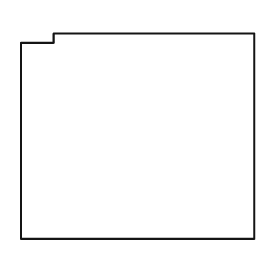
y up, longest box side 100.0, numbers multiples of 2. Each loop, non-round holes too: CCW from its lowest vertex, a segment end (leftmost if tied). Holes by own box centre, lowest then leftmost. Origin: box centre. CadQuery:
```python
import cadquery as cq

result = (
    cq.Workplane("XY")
    .moveTo(-50.0, -44.0)
    .lineTo(50.0, -44.0)
    .lineTo(50.0, 44.0)
    .lineTo(-36.0, 44.0)
    .lineTo(-36.0, 40.0)
    .lineTo(-50.0, 40.0)
    .close()
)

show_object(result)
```